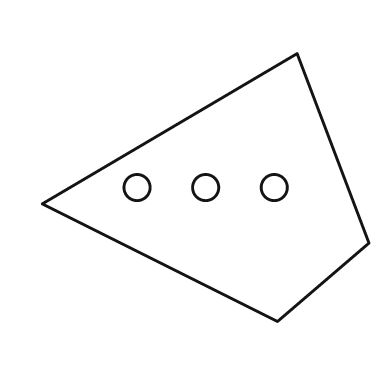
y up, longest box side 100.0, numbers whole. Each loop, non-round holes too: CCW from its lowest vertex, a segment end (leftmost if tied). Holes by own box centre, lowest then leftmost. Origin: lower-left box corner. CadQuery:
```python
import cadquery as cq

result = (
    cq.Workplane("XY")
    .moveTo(72.0, 0.0)
    .lineTo(100.0, 24.0)
    .lineTo(78.0, 82.0)
    .lineTo(0.0, 36.0)
    .close()
    .moveTo(29.0, 41.0)
    .circle(4.0)
    .moveTo(50.0, 41.0)
    .circle(4.0)
    .moveTo(71.0, 41.0)
    .circle(4.0)
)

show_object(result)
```